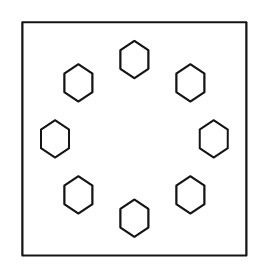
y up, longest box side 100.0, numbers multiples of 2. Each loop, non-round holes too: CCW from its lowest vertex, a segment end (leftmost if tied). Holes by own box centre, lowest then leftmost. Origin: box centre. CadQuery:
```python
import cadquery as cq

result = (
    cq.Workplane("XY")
    .moveTo(-48.0, -50.0)
    .lineTo(48.0, -50.0)
    .lineTo(48.0, 50.0)
    .lineTo(-48.0, 50.0)
    .close()
    .moveTo(0.0, -42.0)
    .lineTo(6.0, -38.0)
    .lineTo(6.0, -30.0)
    .lineTo(0.0, -26.0)
    .lineTo(-6.0, -30.0)
    .lineTo(-6.0, -38.0)
    .close()
    .moveTo(-24.0, -32.0)
    .lineTo(-18.0, -28.0)
    .lineTo(-18.0, -20.0)
    .lineTo(-24.0, -16.0)
    .lineTo(-30.0, -20.0)
    .lineTo(-30.0, -28.0)
    .close()
    .moveTo(24.0, -32.0)
    .lineTo(30.0, -28.0)
    .lineTo(30.0, -20.0)
    .lineTo(24.0, -16.0)
    .lineTo(18.0, -20.0)
    .lineTo(18.0, -28.0)
    .close()
    .moveTo(-34.0, -8.0)
    .lineTo(-28.0, -4.0)
    .lineTo(-28.0, 4.0)
    .lineTo(-34.0, 8.0)
    .lineTo(-40.0, 4.0)
    .lineTo(-40.0, -4.0)
    .close()
    .moveTo(34.0, -8.0)
    .lineTo(40.0, -4.0)
    .lineTo(40.0, 4.0)
    .lineTo(34.0, 8.0)
    .lineTo(28.0, 4.0)
    .lineTo(28.0, -4.0)
    .close()
    .moveTo(-24.0, 16.0)
    .lineTo(-18.0, 20.0)
    .lineTo(-18.0, 28.0)
    .lineTo(-24.0, 32.0)
    .lineTo(-30.0, 28.0)
    .lineTo(-30.0, 20.0)
    .close()
    .moveTo(24.0, 16.0)
    .lineTo(30.0, 20.0)
    .lineTo(30.0, 28.0)
    .lineTo(24.0, 32.0)
    .lineTo(18.0, 28.0)
    .lineTo(18.0, 20.0)
    .close()
    .moveTo(0.0, 26.0)
    .lineTo(6.0, 30.0)
    .lineTo(6.0, 38.0)
    .lineTo(0.0, 42.0)
    .lineTo(-6.0, 38.0)
    .lineTo(-6.0, 30.0)
    .close()
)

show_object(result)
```